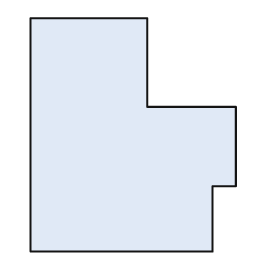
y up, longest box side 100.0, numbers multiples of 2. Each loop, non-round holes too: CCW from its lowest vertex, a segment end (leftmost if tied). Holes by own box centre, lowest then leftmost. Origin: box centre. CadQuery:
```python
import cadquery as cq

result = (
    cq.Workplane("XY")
    .moveTo(-44.0, -50.0)
    .lineTo(34.0, -50.0)
    .lineTo(34.0, -22.0)
    .lineTo(44.0, -22.0)
    .lineTo(44.0, 12.0)
    .lineTo(6.0, 12.0)
    .lineTo(6.0, 50.0)
    .lineTo(-44.0, 50.0)
    .close()
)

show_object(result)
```